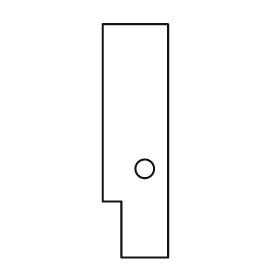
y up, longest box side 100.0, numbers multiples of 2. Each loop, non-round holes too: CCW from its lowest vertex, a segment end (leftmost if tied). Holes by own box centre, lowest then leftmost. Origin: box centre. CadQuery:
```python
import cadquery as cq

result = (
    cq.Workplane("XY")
    .moveTo(-6.0, -50.0)
    .lineTo(14.0, -50.0)
    .lineTo(14.0, 50.0)
    .lineTo(-14.0, 50.0)
    .lineTo(-14.0, -26.0)
    .lineTo(-6.0, -26.0)
    .close()
    .moveTo(4.0, -12.0)
    .circle(4.0)
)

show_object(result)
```